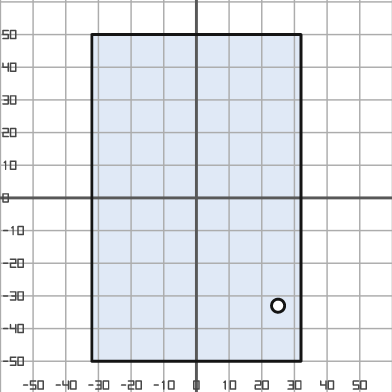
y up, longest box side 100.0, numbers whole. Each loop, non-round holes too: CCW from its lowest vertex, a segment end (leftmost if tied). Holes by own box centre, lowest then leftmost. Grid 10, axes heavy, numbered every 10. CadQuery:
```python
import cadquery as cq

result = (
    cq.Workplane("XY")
    .moveTo(-32.0, -50.0)
    .lineTo(32.0, -50.0)
    .lineTo(32.0, 50.0)
    .lineTo(-32.0, 50.0)
    .close()
    .moveTo(25.0, -33.0)
    .circle(2.0)
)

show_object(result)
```